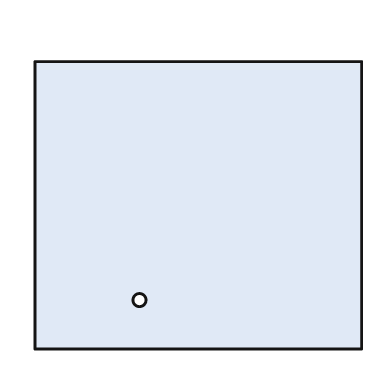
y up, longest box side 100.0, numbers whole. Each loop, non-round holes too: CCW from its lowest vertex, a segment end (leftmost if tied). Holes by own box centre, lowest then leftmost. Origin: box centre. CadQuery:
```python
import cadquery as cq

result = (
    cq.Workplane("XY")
    .moveTo(-50.0, -44.0)
    .lineTo(50.0, -44.0)
    .lineTo(50.0, 44.0)
    .lineTo(-50.0, 44.0)
    .close()
    .moveTo(-18.0, -29.0)
    .circle(2.0)
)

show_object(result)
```